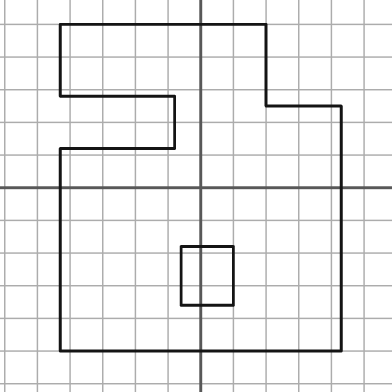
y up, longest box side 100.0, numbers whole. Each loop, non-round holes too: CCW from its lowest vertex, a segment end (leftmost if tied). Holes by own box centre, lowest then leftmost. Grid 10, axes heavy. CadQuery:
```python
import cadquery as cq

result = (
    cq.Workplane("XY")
    .moveTo(-43.0, -50.0)
    .lineTo(43.0, -50.0)
    .lineTo(43.0, 25.0)
    .lineTo(20.0, 25.0)
    .lineTo(20.0, 50.0)
    .lineTo(-43.0, 50.0)
    .lineTo(-43.0, 28.0)
    .lineTo(-8.0, 28.0)
    .lineTo(-8.0, 12.0)
    .lineTo(-43.0, 12.0)
    .close()
    .moveTo(-6.0, -36.0)
    .lineTo(10.0, -36.0)
    .lineTo(10.0, -18.0)
    .lineTo(-6.0, -18.0)
    .close()
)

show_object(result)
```